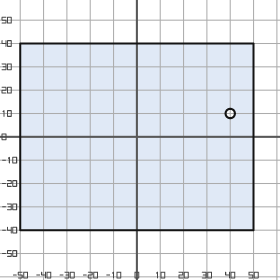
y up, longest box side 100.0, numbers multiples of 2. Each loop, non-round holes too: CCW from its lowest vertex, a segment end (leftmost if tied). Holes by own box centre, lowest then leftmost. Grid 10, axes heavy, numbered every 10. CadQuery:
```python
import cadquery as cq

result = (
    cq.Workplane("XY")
    .moveTo(-50.0, -40.0)
    .lineTo(50.0, -40.0)
    .lineTo(50.0, 40.0)
    .lineTo(-50.0, 40.0)
    .close()
    .moveTo(40.0, 10.0)
    .circle(2.0)
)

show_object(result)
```